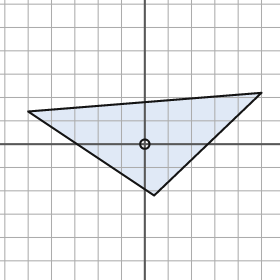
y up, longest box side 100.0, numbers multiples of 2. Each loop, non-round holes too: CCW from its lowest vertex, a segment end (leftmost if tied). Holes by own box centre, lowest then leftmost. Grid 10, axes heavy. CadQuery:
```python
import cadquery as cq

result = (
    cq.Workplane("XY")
    .moveTo(4.0, -22.0)
    .lineTo(50.0, 22.0)
    .lineTo(-50.0, 14.0)
    .close()
    .moveTo(0.0, 0.0)
    .circle(2.0)
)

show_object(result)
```